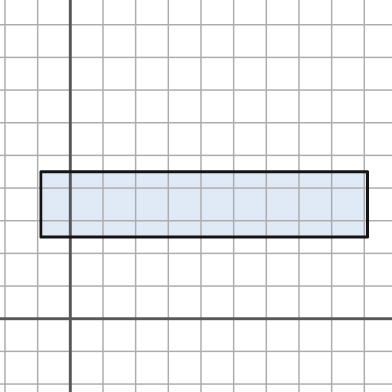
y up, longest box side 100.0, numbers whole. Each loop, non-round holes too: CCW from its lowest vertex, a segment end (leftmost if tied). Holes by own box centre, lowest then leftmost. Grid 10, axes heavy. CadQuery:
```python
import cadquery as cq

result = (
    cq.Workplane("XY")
    .moveTo(-9.0, 25.0)
    .lineTo(91.0, 25.0)
    .lineTo(91.0, 45.0)
    .lineTo(-9.0, 45.0)
    .close()
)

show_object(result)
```